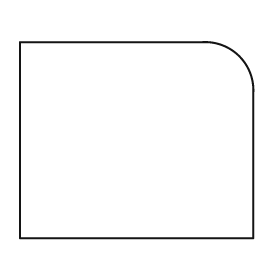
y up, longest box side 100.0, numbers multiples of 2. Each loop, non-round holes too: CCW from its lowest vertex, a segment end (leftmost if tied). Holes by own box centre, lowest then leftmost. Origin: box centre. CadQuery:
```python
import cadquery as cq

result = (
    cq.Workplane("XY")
    .moveTo(-50.0, -42.0)
    .lineTo(50.0, -42.0)
    .lineTo(50.0, 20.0)
    .threePointArc((44.0, 36.0), (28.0, 42.0))
    .lineTo(-50.0, 42.0)
    .close()
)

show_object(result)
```